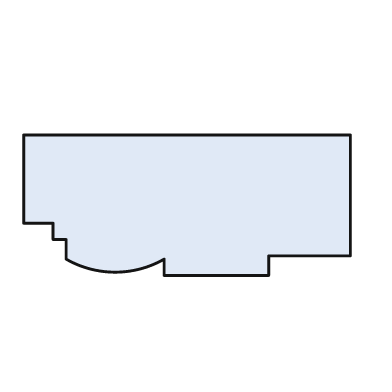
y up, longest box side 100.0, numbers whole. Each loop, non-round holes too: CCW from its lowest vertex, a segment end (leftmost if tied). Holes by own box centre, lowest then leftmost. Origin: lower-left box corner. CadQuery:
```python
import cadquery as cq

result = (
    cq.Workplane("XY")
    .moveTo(43.0, 0.0)
    .lineTo(75.0, 0.0)
    .lineTo(75.0, 6.0)
    .lineTo(100.0, 6.0)
    .lineTo(100.0, 43.0)
    .lineTo(0.0, 43.0)
    .lineTo(0.0, 16.0)
    .lineTo(9.0, 16.0)
    .lineTo(9.0, 11.0)
    .lineTo(13.0, 11.0)
    .lineTo(13.0, 5.0)
    .threePointArc((28.0, 1.0), (43.0, 5.0))
    .close()
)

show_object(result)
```